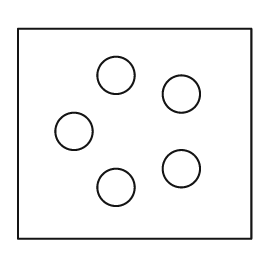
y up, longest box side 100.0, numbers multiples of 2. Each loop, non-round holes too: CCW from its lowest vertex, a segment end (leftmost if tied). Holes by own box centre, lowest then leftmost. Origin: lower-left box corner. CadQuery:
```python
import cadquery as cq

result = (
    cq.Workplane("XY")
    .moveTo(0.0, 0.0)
    .lineTo(100.0, 0.0)
    .lineTo(100.0, 90.0)
    .lineTo(0.0, 90.0)
    .close()
    .moveTo(42.0, 22.0)
    .circle(8.0)
    .moveTo(70.0, 30.0)
    .circle(8.0)
    .moveTo(24.0, 46.0)
    .circle(8.0)
    .moveTo(70.0, 62.0)
    .circle(8.0)
    .moveTo(42.0, 70.0)
    .circle(8.0)
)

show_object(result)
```